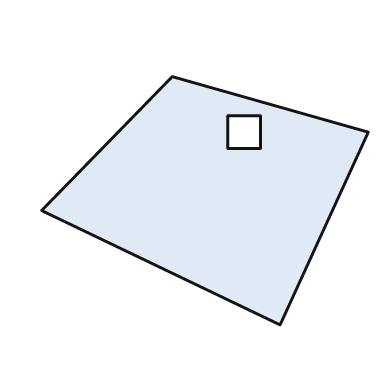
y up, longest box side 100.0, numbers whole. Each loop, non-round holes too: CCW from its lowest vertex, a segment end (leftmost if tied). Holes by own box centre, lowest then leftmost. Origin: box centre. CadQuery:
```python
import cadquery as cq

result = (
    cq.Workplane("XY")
    .moveTo(23.0, -38.0)
    .lineTo(50.0, 21.0)
    .lineTo(-10.0, 38.0)
    .lineTo(-50.0, -3.0)
    .close()
    .moveTo(7.0, 16.0)
    .lineTo(17.0, 16.0)
    .lineTo(17.0, 26.0)
    .lineTo(7.0, 26.0)
    .close()
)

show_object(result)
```